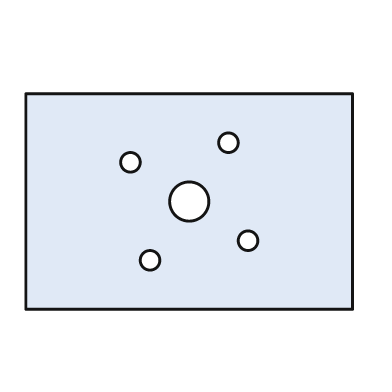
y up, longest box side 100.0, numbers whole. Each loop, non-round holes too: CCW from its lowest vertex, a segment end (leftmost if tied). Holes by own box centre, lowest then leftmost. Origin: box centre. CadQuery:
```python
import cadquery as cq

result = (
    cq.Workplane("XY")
    .moveTo(-50.0, -33.0)
    .lineTo(50.0, -33.0)
    .lineTo(50.0, 33.0)
    .lineTo(-50.0, 33.0)
    .close()
    .moveTo(-12.0, -18.0)
    .circle(3.0)
    .moveTo(18.0, -12.0)
    .circle(3.0)
    .moveTo(0.0, 0.0)
    .circle(6.0)
    .moveTo(-18.0, 12.0)
    .circle(3.0)
    .moveTo(12.0, 18.0)
    .circle(3.0)
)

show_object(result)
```